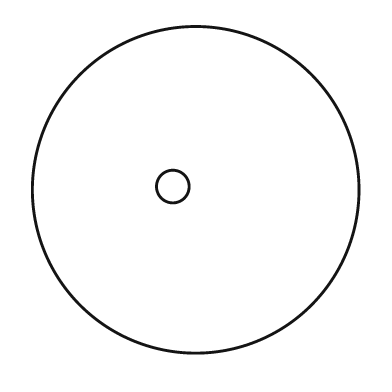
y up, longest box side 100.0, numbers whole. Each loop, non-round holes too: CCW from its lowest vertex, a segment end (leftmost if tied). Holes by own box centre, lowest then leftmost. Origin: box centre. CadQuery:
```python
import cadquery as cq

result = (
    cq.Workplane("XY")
    .moveTo(0.0, 0.0)
    .circle(50.0)
    .moveTo(-7.0, 1.0)
    .circle(5.0)
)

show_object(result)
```